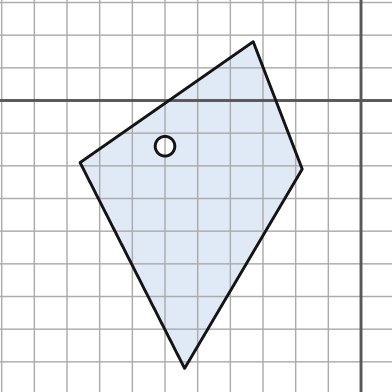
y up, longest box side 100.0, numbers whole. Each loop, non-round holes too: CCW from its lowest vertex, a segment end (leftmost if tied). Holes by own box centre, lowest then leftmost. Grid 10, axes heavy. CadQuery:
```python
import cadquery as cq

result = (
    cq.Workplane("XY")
    .moveTo(-54.0, -82.0)
    .lineTo(-18.0, -21.0)
    .lineTo(-33.0, 18.0)
    .lineTo(-86.0, -19.0)
    .close()
    .moveTo(-60.0, -14.0)
    .circle(3.0)
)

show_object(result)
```